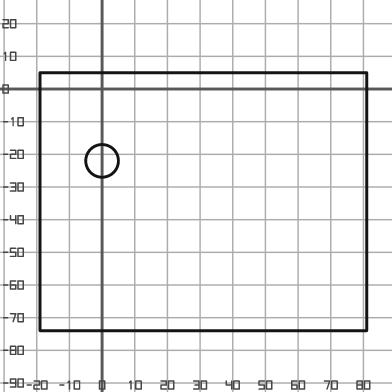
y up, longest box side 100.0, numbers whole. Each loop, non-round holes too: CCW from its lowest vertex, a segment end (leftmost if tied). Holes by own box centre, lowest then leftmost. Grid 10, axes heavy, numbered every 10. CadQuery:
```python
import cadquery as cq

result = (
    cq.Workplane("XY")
    .moveTo(-19.0, -74.0)
    .lineTo(81.0, -74.0)
    .lineTo(81.0, 5.0)
    .lineTo(-19.0, 5.0)
    .close()
    .moveTo(0.0, -22.0)
    .circle(5.0)
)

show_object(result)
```